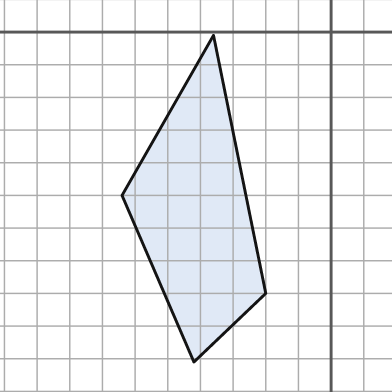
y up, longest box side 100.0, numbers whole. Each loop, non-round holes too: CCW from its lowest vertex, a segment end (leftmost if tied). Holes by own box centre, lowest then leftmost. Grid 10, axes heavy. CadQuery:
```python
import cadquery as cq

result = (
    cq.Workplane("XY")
    .moveTo(-42.0, -101.0)
    .lineTo(-20.0, -80.0)
    .lineTo(-36.0, -1.0)
    .lineTo(-64.0, -50.0)
    .close()
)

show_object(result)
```